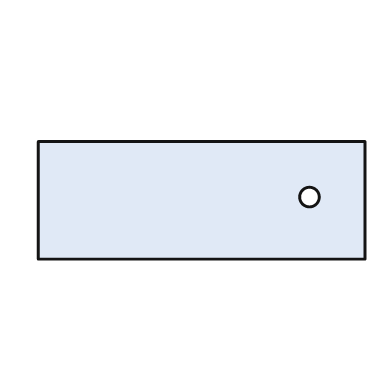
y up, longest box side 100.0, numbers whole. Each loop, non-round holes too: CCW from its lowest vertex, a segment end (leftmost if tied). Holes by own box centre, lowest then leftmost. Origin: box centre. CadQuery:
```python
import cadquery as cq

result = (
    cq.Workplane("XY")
    .moveTo(-50.0, -18.0)
    .lineTo(50.0, -18.0)
    .lineTo(50.0, 18.0)
    .lineTo(-50.0, 18.0)
    .close()
    .moveTo(33.0, 1.0)
    .circle(3.0)
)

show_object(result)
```